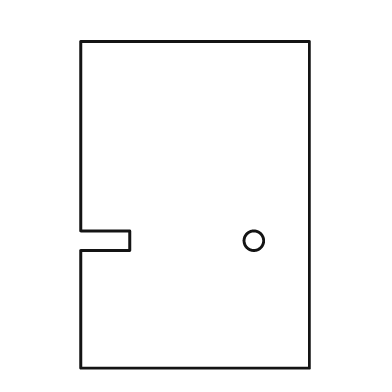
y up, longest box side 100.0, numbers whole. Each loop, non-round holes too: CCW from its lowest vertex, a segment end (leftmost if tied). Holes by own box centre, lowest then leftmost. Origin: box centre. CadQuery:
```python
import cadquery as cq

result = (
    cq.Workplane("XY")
    .moveTo(-35.0, -50.0)
    .lineTo(35.0, -50.0)
    .lineTo(35.0, 50.0)
    .lineTo(-35.0, 50.0)
    .lineTo(-35.0, -8.0)
    .lineTo(-20.0, -8.0)
    .lineTo(-20.0, -14.0)
    .lineTo(-35.0, -14.0)
    .close()
    .moveTo(18.0, -11.0)
    .circle(3.0)
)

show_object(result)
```